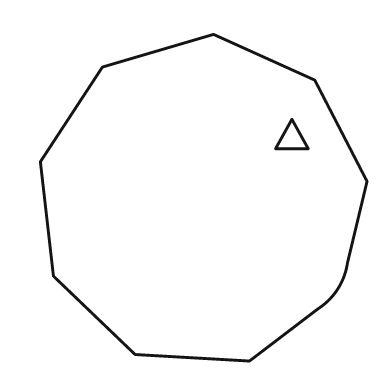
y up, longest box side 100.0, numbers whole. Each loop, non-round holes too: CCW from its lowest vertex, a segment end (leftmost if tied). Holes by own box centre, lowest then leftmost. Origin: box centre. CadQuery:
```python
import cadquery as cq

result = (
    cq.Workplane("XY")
    .moveTo(14.0, -50.0)
    .lineTo(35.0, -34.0)
    .threePointArc((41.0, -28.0), (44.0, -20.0))
    .lineTo(50.0, 5.0)
    .lineTo(34.0, 36.0)
    .lineTo(3.0, 50.0)
    .lineTo(-31.0, 40.0)
    .lineTo(-50.0, 11.0)
    .lineTo(-46.0, -24.0)
    .lineTo(-21.0, -48.0)
    .close()
    .moveTo(22.0, 15.0)
    .lineTo(32.0, 15.0)
    .lineTo(27.0, 24.0)
    .close()
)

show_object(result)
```